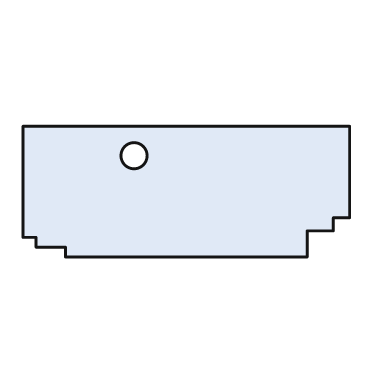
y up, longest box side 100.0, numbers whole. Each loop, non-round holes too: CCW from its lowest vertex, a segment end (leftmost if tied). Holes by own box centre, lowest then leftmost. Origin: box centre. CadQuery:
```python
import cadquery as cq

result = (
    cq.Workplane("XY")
    .moveTo(-37.0, -20.0)
    .lineTo(37.0, -20.0)
    .lineTo(37.0, -12.0)
    .lineTo(45.0, -12.0)
    .lineTo(45.0, -8.0)
    .lineTo(50.0, -8.0)
    .lineTo(50.0, 20.0)
    .lineTo(-50.0, 20.0)
    .lineTo(-50.0, -14.0)
    .lineTo(-46.0, -14.0)
    .lineTo(-46.0, -17.0)
    .lineTo(-37.0, -17.0)
    .close()
    .moveTo(-16.0, 11.0)
    .circle(4.0)
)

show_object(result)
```